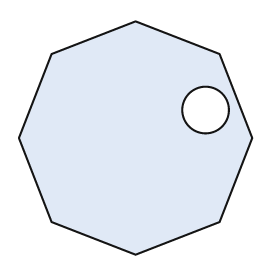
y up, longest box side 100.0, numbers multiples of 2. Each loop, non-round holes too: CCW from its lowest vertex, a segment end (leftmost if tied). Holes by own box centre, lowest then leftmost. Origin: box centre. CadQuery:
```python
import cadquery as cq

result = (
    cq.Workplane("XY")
    .moveTo(0.0, -50.0)
    .lineTo(36.0, -36.0)
    .lineTo(50.0, 0.0)
    .lineTo(36.0, 36.0)
    .lineTo(0.0, 50.0)
    .lineTo(-36.0, 36.0)
    .lineTo(-50.0, 0.0)
    .lineTo(-36.0, -36.0)
    .close()
    .moveTo(30.0, 12.0)
    .circle(10.0)
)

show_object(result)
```